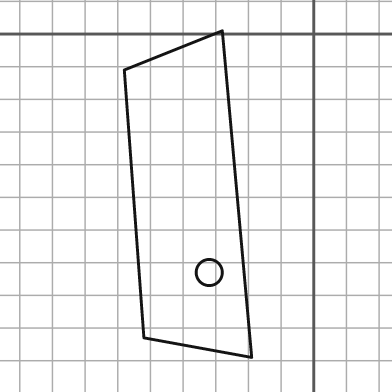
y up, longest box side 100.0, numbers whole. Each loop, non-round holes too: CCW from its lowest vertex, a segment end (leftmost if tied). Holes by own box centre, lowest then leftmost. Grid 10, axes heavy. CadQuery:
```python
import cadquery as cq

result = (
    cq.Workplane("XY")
    .moveTo(-19.0, -99.0)
    .lineTo(-28.0, 1.0)
    .lineTo(-58.0, -11.0)
    .lineTo(-52.0, -93.0)
    .close()
    .moveTo(-32.0, -73.0)
    .circle(4.0)
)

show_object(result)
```